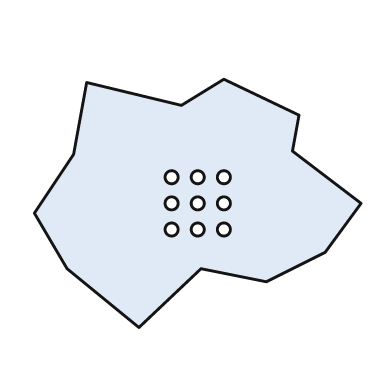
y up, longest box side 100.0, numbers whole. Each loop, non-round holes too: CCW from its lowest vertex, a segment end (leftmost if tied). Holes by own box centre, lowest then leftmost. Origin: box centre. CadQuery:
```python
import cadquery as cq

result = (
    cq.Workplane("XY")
    .moveTo(-18.0, -38.0)
    .lineTo(1.0, -20.0)
    .lineTo(21.0, -24.0)
    .lineTo(39.0, -15.0)
    .lineTo(50.0, 0.0)
    .lineTo(29.0, 16.0)
    .lineTo(31.0, 27.0)
    .lineTo(8.0, 38.0)
    .lineTo(-5.0, 30.0)
    .lineTo(-34.0, 37.0)
    .lineTo(-38.0, 15.0)
    .lineTo(-50.0, -3.0)
    .lineTo(-40.0, -20.0)
    .close()
    .moveTo(-8.0, -8.0)
    .circle(2.0)
    .moveTo(0.0, -8.0)
    .circle(2.0)
    .moveTo(8.0, -8.0)
    .circle(2.0)
    .moveTo(-8.0, 0.0)
    .circle(2.0)
    .moveTo(0.0, 0.0)
    .circle(2.0)
    .moveTo(8.0, 0.0)
    .circle(2.0)
    .moveTo(-8.0, 8.0)
    .circle(2.0)
    .moveTo(0.0, 8.0)
    .circle(2.0)
    .moveTo(8.0, 8.0)
    .circle(2.0)
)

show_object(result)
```